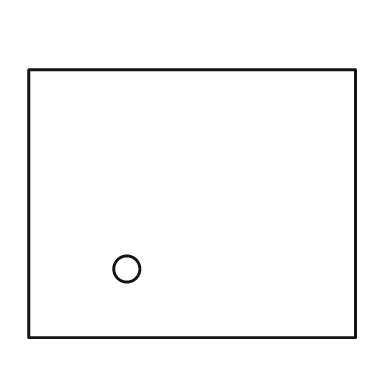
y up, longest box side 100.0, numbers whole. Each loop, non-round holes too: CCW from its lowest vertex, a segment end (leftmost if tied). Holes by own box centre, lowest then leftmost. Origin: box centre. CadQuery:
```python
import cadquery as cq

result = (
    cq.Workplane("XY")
    .moveTo(-50.0, -41.0)
    .lineTo(50.0, -41.0)
    .lineTo(50.0, 41.0)
    .lineTo(-50.0, 41.0)
    .close()
    .moveTo(-20.0, -20.0)
    .circle(4.0)
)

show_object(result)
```